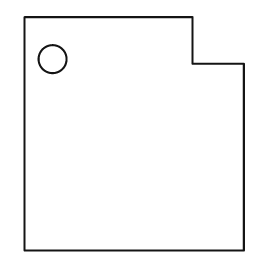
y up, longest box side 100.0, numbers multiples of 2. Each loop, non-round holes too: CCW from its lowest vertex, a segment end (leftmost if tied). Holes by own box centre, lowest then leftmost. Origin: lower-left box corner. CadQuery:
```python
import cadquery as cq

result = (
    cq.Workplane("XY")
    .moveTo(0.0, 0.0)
    .lineTo(94.0, 0.0)
    .lineTo(94.0, 80.0)
    .lineTo(72.0, 80.0)
    .lineTo(72.0, 100.0)
    .lineTo(0.0, 100.0)
    .close()
    .moveTo(12.0, 82.0)
    .circle(6.0)
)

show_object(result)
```